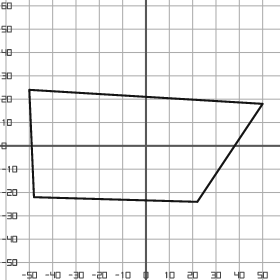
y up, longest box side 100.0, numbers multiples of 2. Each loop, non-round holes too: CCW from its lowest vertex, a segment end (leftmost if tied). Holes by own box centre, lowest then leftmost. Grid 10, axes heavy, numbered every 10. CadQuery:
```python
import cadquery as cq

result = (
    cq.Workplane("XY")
    .moveTo(22.0, -24.0)
    .lineTo(50.0, 18.0)
    .lineTo(-50.0, 24.0)
    .lineTo(-48.0, -22.0)
    .close()
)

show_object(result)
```